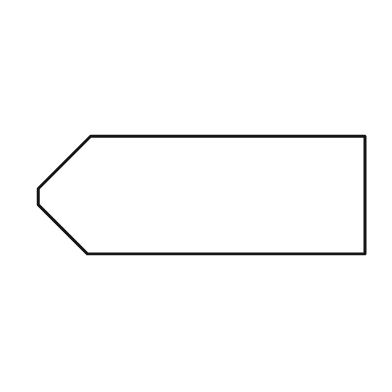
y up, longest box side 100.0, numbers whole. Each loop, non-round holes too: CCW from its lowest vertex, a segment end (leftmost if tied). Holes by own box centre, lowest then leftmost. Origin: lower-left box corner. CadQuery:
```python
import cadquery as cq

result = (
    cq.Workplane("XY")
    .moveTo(15.0, 0.0)
    .lineTo(100.0, 0.0)
    .lineTo(100.0, 36.0)
    .lineTo(16.0, 36.0)
    .lineTo(0.0, 20.0)
    .lineTo(0.0, 15.0)
    .close()
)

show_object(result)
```